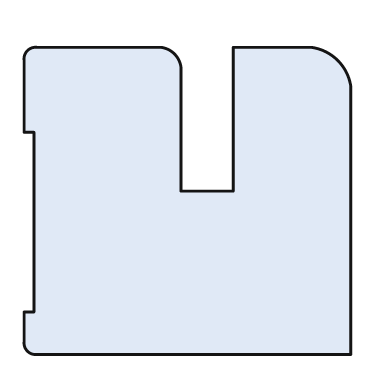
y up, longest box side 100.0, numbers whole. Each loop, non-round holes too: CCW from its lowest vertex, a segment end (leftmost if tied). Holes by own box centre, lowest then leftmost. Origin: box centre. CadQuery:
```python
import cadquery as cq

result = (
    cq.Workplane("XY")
    .moveTo(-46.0, -47.0)
    .lineTo(50.0, -47.0)
    .lineTo(50.0, 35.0)
    .threePointArc((46.0, 43.0), (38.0, 47.0))
    .lineTo(14.0, 47.0)
    .lineTo(14.0, 3.0)
    .lineTo(-2.0, 3.0)
    .lineTo(-2.0, 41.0)
    .threePointArc((-4.0, 45.0), (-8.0, 47.0))
    .lineTo(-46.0, 47.0)
    .threePointArc((-49.0, 46.0), (-50.0, 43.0))
    .lineTo(-50.0, 21.0)
    .lineTo(-47.0, 21.0)
    .lineTo(-47.0, -34.0)
    .lineTo(-50.0, -34.0)
    .lineTo(-50.0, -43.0)
    .threePointArc((-49.0, -46.0), (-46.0, -47.0))
    .close()
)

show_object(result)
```